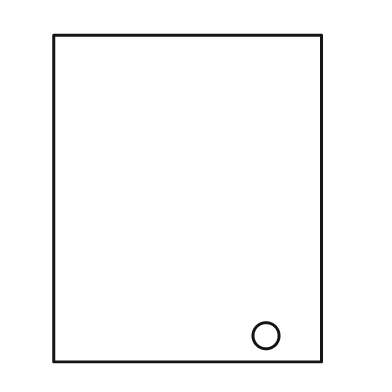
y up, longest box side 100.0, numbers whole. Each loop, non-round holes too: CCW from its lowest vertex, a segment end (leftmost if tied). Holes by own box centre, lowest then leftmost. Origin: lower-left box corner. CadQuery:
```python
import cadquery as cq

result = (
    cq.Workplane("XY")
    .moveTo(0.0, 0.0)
    .lineTo(82.0, 0.0)
    .lineTo(82.0, 100.0)
    .lineTo(0.0, 100.0)
    .close()
    .moveTo(65.0, 8.0)
    .circle(4.0)
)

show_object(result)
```